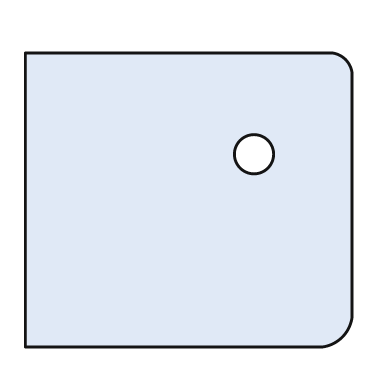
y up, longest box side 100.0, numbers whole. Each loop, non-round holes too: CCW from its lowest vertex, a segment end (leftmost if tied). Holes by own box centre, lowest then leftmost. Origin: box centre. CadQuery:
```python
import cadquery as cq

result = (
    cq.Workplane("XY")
    .moveTo(-50.0, -45.0)
    .lineTo(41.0, -45.0)
    .threePointArc((47.0, -42.0), (50.0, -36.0))
    .lineTo(50.0, 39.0)
    .threePointArc((48.0, 43.0), (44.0, 45.0))
    .lineTo(-50.0, 45.0)
    .close()
    .moveTo(20.0, 14.0)
    .circle(6.0)
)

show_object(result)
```